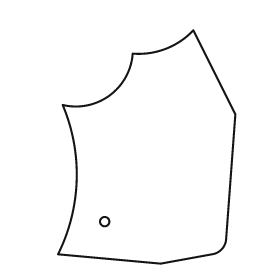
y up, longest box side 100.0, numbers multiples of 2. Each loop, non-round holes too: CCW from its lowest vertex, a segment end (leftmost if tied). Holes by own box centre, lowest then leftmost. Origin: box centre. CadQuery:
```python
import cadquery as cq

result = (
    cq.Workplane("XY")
    .moveTo(6.0, -50.0)
    .lineTo(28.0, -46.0)
    .threePointArc((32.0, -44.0), (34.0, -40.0))
    .lineTo(38.0, 14.0)
    .lineTo(20.0, 50.0)
    .threePointArc((8.0, 42.0), (-6.0, 40.0))
    .threePointArc((-16.0, 22.0), (-36.0, 18.0))
    .threePointArc((-30.0, -14.0), (-38.0, -46.0))
    .close()
    .moveTo(-18.0, -32.0)
    .circle(2.0)
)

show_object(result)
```